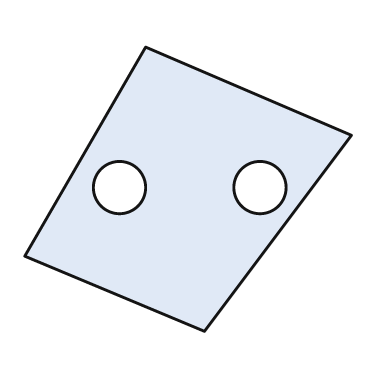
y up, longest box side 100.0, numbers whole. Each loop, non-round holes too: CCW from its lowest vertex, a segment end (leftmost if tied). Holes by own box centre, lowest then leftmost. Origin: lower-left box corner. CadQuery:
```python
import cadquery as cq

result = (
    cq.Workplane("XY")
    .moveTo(55.0, 0.0)
    .lineTo(100.0, 60.0)
    .lineTo(37.0, 87.0)
    .lineTo(0.0, 23.0)
    .close()
    .moveTo(29.0, 44.0)
    .circle(8.0)
    .moveTo(72.0, 44.0)
    .circle(8.0)
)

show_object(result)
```